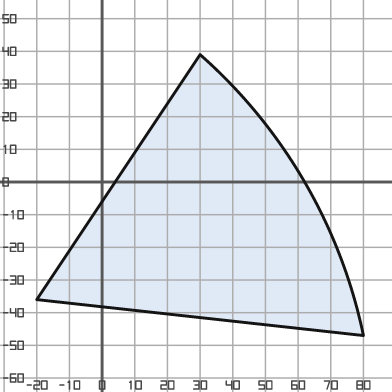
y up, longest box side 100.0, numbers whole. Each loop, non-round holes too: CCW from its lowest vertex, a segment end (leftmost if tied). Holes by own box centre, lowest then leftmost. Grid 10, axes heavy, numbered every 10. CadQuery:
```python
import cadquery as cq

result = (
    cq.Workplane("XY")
    .moveTo(80.0, -47.0)
    .threePointArc((62.0, 0.0), (30.0, 39.0))
    .lineTo(-20.0, -36.0)
    .close()
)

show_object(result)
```